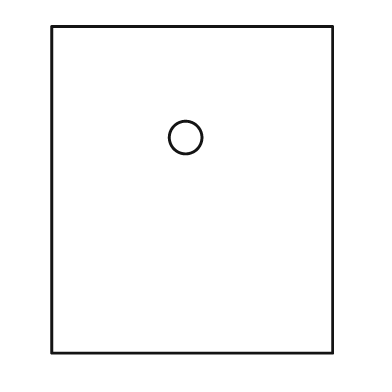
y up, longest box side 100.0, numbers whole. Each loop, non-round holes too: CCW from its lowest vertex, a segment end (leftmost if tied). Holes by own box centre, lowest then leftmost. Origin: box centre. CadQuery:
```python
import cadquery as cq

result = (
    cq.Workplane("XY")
    .moveTo(-43.0, -50.0)
    .lineTo(43.0, -50.0)
    .lineTo(43.0, 50.0)
    .lineTo(-43.0, 50.0)
    .close()
    .moveTo(-2.0, 16.0)
    .circle(5.0)
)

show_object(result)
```